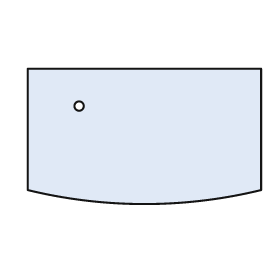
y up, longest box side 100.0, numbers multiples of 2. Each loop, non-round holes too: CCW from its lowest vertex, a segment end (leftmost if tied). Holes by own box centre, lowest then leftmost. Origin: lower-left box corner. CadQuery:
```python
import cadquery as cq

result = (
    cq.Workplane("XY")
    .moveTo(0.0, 6.0)
    .threePointArc((50.0, 0.0), (100.0, 6.0))
    .lineTo(100.0, 58.0)
    .lineTo(0.0, 58.0)
    .close()
    .moveTo(22.0, 42.0)
    .circle(2.0)
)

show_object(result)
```